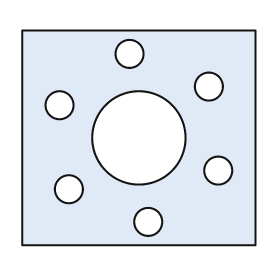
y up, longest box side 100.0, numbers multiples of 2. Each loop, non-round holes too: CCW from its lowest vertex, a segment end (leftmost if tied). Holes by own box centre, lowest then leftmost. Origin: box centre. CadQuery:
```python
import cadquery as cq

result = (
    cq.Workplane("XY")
    .moveTo(-50.0, -46.0)
    .lineTo(50.0, -46.0)
    .lineTo(50.0, 46.0)
    .lineTo(-50.0, 46.0)
    .close()
    .moveTo(4.0, -36.0)
    .circle(6.0)
    .moveTo(-30.0, -22.0)
    .circle(6.0)
    .moveTo(34.0, -14.0)
    .circle(6.0)
    .moveTo(0.0, 0.0)
    .circle(20.0)
    .moveTo(-34.0, 14.0)
    .circle(6.0)
    .moveTo(30.0, 22.0)
    .circle(6.0)
    .moveTo(-4.0, 36.0)
    .circle(6.0)
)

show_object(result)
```